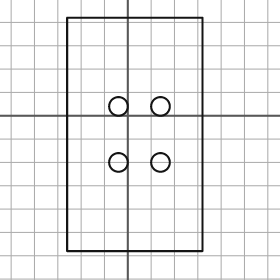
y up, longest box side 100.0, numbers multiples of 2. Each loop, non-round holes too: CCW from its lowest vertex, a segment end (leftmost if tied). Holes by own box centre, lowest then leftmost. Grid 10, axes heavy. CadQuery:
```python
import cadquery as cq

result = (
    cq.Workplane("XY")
    .moveTo(-26.0, -58.0)
    .lineTo(32.0, -58.0)
    .lineTo(32.0, 42.0)
    .lineTo(-26.0, 42.0)
    .close()
    .moveTo(-4.0, -20.0)
    .circle(4.0)
    .moveTo(14.0, -20.0)
    .circle(4.0)
    .moveTo(-4.0, 4.0)
    .circle(4.0)
    .moveTo(14.0, 4.0)
    .circle(4.0)
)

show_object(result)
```